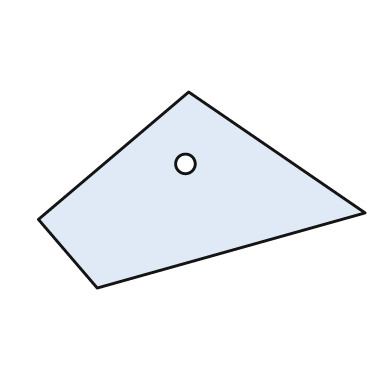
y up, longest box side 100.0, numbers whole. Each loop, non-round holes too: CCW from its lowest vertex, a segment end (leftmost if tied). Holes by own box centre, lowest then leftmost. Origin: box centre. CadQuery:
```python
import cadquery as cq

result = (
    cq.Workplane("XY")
    .moveTo(-32.0, -30.0)
    .lineTo(50.0, -7.0)
    .lineTo(-4.0, 30.0)
    .lineTo(-50.0, -9.0)
    .close()
    .moveTo(-5.0, 8.0)
    .circle(3.0)
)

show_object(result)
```